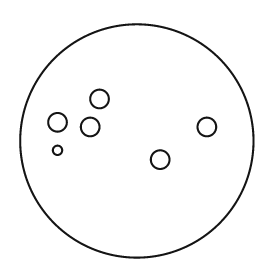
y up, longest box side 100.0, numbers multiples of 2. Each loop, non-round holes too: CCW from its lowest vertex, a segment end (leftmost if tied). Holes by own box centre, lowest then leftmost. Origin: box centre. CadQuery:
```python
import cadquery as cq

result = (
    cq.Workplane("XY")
    .moveTo(0.0, 0.0)
    .circle(50.0)
    .moveTo(10.0, -8.0)
    .circle(4.0)
    .moveTo(-34.0, -4.0)
    .circle(2.0)
    .moveTo(-20.0, 6.0)
    .circle(4.0)
    .moveTo(30.0, 6.0)
    .circle(4.0)
    .moveTo(-34.0, 8.0)
    .circle(4.0)
    .moveTo(-16.0, 18.0)
    .circle(4.0)
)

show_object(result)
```